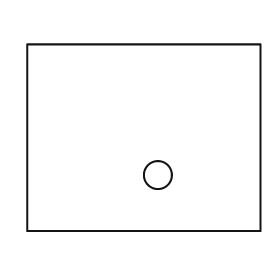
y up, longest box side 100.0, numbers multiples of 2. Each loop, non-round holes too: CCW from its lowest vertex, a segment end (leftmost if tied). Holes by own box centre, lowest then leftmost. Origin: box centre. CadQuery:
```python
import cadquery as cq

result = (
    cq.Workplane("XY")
    .moveTo(-50.0, -40.0)
    .lineTo(50.0, -40.0)
    .lineTo(50.0, 40.0)
    .lineTo(-50.0, 40.0)
    .close()
    .moveTo(6.0, -16.0)
    .circle(6.0)
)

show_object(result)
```